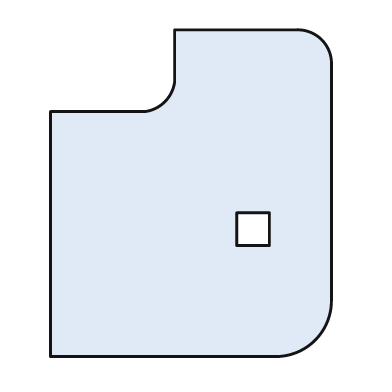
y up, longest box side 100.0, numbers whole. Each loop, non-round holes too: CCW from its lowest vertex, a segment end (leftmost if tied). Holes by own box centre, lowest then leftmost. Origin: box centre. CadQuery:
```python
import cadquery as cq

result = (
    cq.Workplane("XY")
    .moveTo(-43.0, -50.0)
    .lineTo(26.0, -50.0)
    .threePointArc((38.0, -45.0), (43.0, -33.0))
    .lineTo(43.0, 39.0)
    .threePointArc((40.0, 47.0), (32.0, 50.0))
    .lineTo(-5.0, 50.0)
    .lineTo(-5.0, 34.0)
    .threePointArc((-8.0, 28.0), (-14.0, 25.0))
    .lineTo(-43.0, 25.0)
    .close()
    .moveTo(14.0, -16.0)
    .lineTo(24.0, -16.0)
    .lineTo(24.0, -6.0)
    .lineTo(14.0, -6.0)
    .close()
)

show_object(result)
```